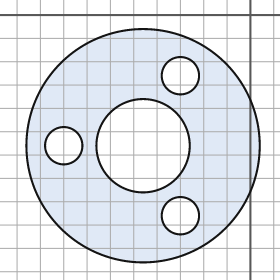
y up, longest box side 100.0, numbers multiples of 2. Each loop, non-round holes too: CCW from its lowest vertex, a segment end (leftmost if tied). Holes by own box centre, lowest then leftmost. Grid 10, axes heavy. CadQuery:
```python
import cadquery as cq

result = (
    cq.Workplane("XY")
    .moveTo(-46.0, -56.0)
    .circle(50.0)
    .moveTo(-30.0, -86.0)
    .circle(8.0)
    .moveTo(-80.0, -56.0)
    .circle(8.0)
    .moveTo(-46.0, -56.0)
    .circle(20.0)
    .moveTo(-30.0, -26.0)
    .circle(8.0)
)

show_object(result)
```